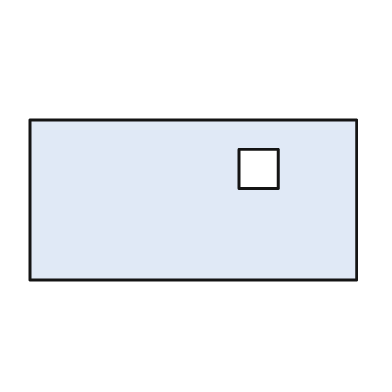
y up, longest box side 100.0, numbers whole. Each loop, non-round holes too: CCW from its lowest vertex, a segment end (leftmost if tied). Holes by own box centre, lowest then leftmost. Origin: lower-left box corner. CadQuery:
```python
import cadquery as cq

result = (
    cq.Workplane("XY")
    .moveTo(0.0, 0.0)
    .lineTo(100.0, 0.0)
    .lineTo(100.0, 49.0)
    .lineTo(0.0, 49.0)
    .close()
    .moveTo(64.0, 28.0)
    .lineTo(76.0, 28.0)
    .lineTo(76.0, 40.0)
    .lineTo(64.0, 40.0)
    .close()
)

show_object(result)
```